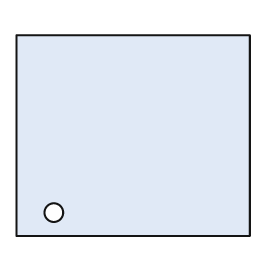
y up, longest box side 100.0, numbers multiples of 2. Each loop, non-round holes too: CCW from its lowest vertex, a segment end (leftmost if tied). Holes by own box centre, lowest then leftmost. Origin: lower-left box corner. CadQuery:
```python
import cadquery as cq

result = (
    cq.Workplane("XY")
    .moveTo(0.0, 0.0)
    .lineTo(100.0, 0.0)
    .lineTo(100.0, 86.0)
    .lineTo(0.0, 86.0)
    .close()
    .moveTo(16.0, 10.0)
    .circle(4.0)
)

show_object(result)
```